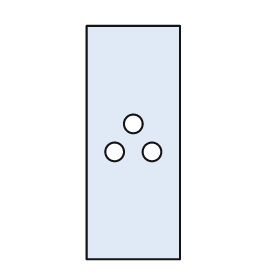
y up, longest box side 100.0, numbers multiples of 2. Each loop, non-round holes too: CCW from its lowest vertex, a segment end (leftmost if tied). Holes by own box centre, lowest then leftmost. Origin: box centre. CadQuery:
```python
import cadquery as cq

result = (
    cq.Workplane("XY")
    .moveTo(-20.0, -50.0)
    .lineTo(20.0, -50.0)
    .lineTo(20.0, 50.0)
    .lineTo(-20.0, 50.0)
    .close()
    .moveTo(-8.0, -4.0)
    .circle(4.0)
    .moveTo(8.0, -4.0)
    .circle(4.0)
    .moveTo(0.0, 8.0)
    .circle(4.0)
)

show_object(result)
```